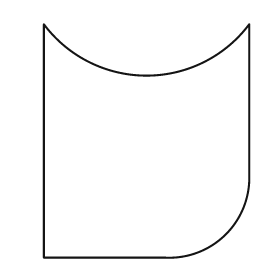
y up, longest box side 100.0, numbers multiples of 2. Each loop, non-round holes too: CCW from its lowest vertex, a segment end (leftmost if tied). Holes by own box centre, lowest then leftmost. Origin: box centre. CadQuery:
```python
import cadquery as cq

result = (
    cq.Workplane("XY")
    .moveTo(-44.0, -50.0)
    .lineTo(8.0, -50.0)
    .threePointArc((34.0, -40.0), (44.0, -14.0))
    .lineTo(44.0, 50.0)
    .threePointArc((0.0, 28.0), (-44.0, 50.0))
    .close()
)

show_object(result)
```